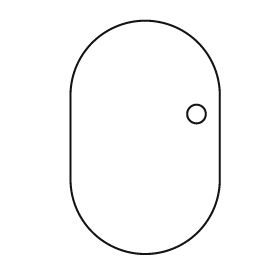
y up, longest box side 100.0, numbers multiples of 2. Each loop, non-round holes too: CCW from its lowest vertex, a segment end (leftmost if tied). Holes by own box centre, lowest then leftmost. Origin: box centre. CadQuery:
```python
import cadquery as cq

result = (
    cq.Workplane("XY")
    .moveTo(-32.0, -18.0)
    .threePointArc((0.0, -50.0), (32.0, -18.0))
    .lineTo(32.0, 18.0)
    .threePointArc((0.0, 50.0), (-32.0, 18.0))
    .close()
    .moveTo(22.0, 10.0)
    .circle(4.0)
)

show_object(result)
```